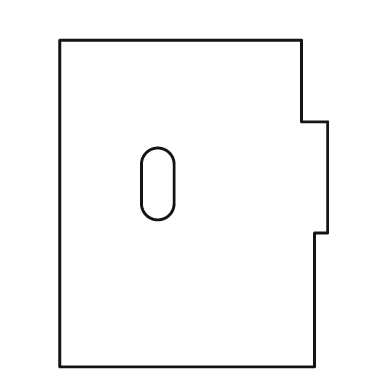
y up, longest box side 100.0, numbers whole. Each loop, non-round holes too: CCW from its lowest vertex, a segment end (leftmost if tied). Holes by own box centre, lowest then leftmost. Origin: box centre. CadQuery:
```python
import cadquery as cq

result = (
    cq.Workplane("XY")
    .moveTo(-41.0, -50.0)
    .lineTo(37.0, -50.0)
    .lineTo(37.0, -9.0)
    .lineTo(41.0, -9.0)
    .lineTo(41.0, 25.0)
    .lineTo(33.0, 25.0)
    .lineTo(33.0, 50.0)
    .lineTo(-41.0, 50.0)
    .close()
    .moveTo(-16.0, 0.0)
    .threePointArc((-11.0, -5.0), (-6.0, 0.0))
    .lineTo(-6.0, 12.0)
    .threePointArc((-11.0, 17.0), (-16.0, 12.0))
    .close()
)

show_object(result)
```